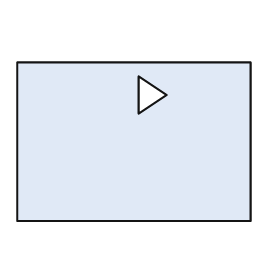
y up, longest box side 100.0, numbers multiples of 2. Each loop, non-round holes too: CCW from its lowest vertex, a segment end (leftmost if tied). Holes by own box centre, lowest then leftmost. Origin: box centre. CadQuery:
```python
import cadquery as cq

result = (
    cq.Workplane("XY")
    .moveTo(-50.0, -34.0)
    .lineTo(50.0, -34.0)
    .lineTo(50.0, 34.0)
    .lineTo(-50.0, 34.0)
    .close()
    .moveTo(2.0, 12.0)
    .lineTo(14.0, 20.0)
    .lineTo(2.0, 28.0)
    .close()
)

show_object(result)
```